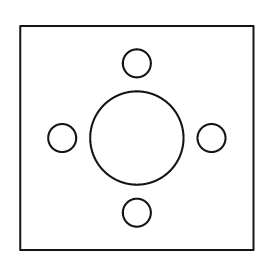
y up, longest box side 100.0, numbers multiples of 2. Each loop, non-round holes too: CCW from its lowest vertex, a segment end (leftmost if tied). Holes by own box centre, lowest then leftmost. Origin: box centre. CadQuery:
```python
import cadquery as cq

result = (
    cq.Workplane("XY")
    .moveTo(-50.0, -48.0)
    .lineTo(50.0, -48.0)
    .lineTo(50.0, 48.0)
    .lineTo(-50.0, 48.0)
    .close()
    .moveTo(0.0, -32.0)
    .circle(6.0)
    .moveTo(-32.0, 0.0)
    .circle(6.0)
    .moveTo(0.0, 0.0)
    .circle(20.0)
    .moveTo(32.0, 0.0)
    .circle(6.0)
    .moveTo(0.0, 32.0)
    .circle(6.0)
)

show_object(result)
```